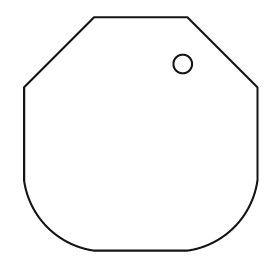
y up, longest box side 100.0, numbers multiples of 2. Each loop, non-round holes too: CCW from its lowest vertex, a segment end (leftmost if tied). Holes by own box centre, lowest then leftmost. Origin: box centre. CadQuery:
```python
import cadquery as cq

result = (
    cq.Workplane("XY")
    .moveTo(-20.0, -50.0)
    .lineTo(20.0, -50.0)
    .threePointArc((40.0, -40.0), (50.0, -20.0))
    .lineTo(50.0, 20.0)
    .lineTo(20.0, 50.0)
    .lineTo(-20.0, 50.0)
    .lineTo(-50.0, 20.0)
    .lineTo(-50.0, -20.0)
    .threePointArc((-40.0, -40.0), (-20.0, -50.0))
    .close()
    .moveTo(18.0, 30.0)
    .circle(4.0)
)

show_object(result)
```